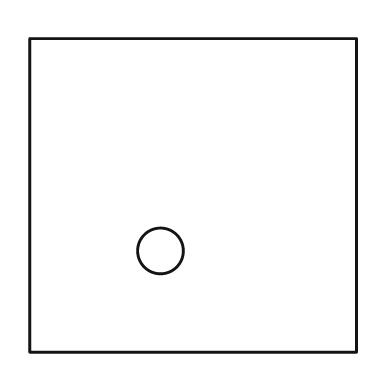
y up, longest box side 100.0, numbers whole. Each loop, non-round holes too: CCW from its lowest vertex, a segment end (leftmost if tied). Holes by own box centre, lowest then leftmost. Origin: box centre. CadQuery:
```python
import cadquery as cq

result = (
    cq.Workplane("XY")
    .moveTo(-50.0, -48.0)
    .lineTo(50.0, -48.0)
    .lineTo(50.0, 48.0)
    .lineTo(-50.0, 48.0)
    .close()
    .moveTo(-10.0, -17.0)
    .circle(7.0)
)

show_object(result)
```